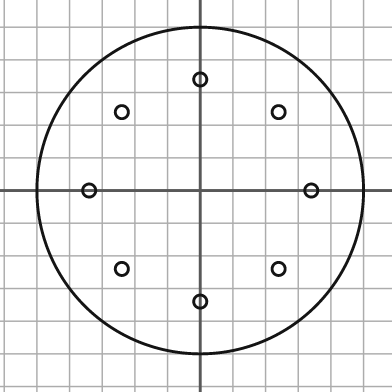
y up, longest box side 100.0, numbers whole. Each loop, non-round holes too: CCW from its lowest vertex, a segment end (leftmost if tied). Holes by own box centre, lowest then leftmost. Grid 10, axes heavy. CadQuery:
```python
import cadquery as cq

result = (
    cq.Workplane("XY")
    .moveTo(0.0, 0.0)
    .circle(50.0)
    .moveTo(0.0, -34.0)
    .circle(2.0)
    .moveTo(-24.0, -24.0)
    .circle(2.0)
    .moveTo(24.0, -24.0)
    .circle(2.0)
    .moveTo(-34.0, 0.0)
    .circle(2.0)
    .moveTo(34.0, 0.0)
    .circle(2.0)
    .moveTo(-24.0, 24.0)
    .circle(2.0)
    .moveTo(24.0, 24.0)
    .circle(2.0)
    .moveTo(0.0, 34.0)
    .circle(2.0)
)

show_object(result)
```